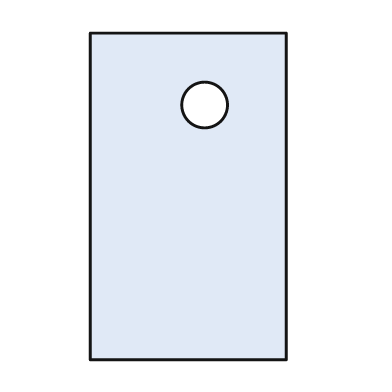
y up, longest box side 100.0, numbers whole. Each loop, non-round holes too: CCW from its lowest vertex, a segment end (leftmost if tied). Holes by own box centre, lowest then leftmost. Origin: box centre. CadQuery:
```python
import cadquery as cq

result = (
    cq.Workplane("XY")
    .moveTo(-30.0, -50.0)
    .lineTo(30.0, -50.0)
    .lineTo(30.0, 50.0)
    .lineTo(-30.0, 50.0)
    .close()
    .moveTo(5.0, 28.0)
    .circle(7.0)
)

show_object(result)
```